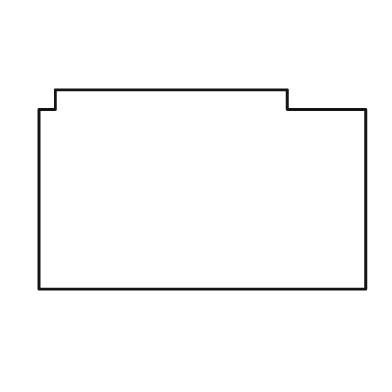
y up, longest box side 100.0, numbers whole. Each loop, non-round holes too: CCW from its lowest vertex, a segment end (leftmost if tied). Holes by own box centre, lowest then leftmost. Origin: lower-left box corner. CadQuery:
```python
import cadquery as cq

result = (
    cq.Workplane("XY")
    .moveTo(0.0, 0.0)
    .lineTo(100.0, 0.0)
    .lineTo(100.0, 55.0)
    .lineTo(76.0, 55.0)
    .lineTo(76.0, 61.0)
    .lineTo(5.0, 61.0)
    .lineTo(5.0, 55.0)
    .lineTo(0.0, 55.0)
    .close()
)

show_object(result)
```